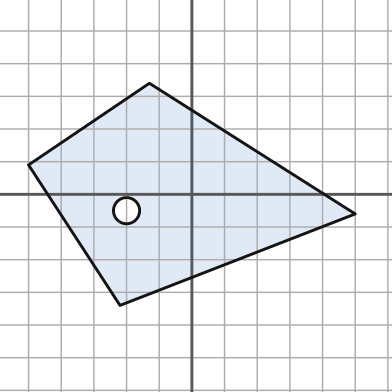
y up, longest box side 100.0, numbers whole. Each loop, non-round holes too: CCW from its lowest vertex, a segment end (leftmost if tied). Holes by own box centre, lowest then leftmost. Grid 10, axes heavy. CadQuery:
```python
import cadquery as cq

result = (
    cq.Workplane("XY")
    .moveTo(-22.0, -34.0)
    .lineTo(50.0, -6.0)
    .lineTo(-13.0, 34.0)
    .lineTo(-50.0, 9.0)
    .close()
    .moveTo(-20.0, -5.0)
    .circle(4.0)
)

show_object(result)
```